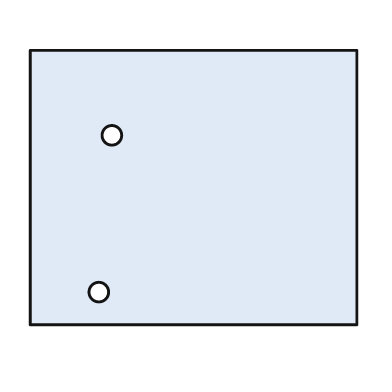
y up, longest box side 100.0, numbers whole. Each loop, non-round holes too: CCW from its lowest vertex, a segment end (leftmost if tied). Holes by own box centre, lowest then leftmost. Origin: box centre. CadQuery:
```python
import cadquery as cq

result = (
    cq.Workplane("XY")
    .moveTo(-50.0, -42.0)
    .lineTo(50.0, -42.0)
    .lineTo(50.0, 42.0)
    .lineTo(-50.0, 42.0)
    .close()
    .moveTo(-29.0, -32.0)
    .circle(3.0)
    .moveTo(-25.0, 16.0)
    .circle(3.0)
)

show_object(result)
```